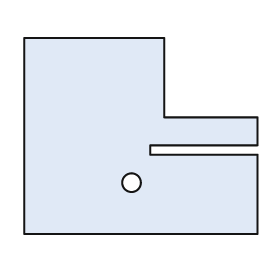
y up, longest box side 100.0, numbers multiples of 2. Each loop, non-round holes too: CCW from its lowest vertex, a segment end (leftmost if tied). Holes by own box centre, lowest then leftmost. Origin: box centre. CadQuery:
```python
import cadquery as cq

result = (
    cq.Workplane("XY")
    .moveTo(-50.0, -42.0)
    .lineTo(50.0, -42.0)
    .lineTo(50.0, -8.0)
    .lineTo(4.0, -8.0)
    .lineTo(4.0, -4.0)
    .lineTo(50.0, -4.0)
    .lineTo(50.0, 8.0)
    .lineTo(10.0, 8.0)
    .lineTo(10.0, 42.0)
    .lineTo(-50.0, 42.0)
    .close()
    .moveTo(-4.0, -20.0)
    .circle(4.0)
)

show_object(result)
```